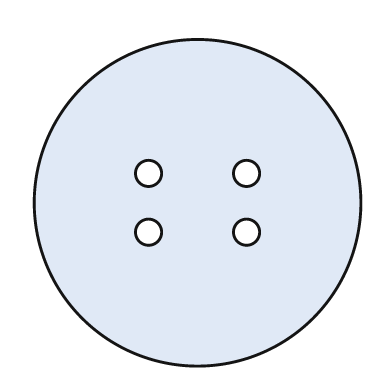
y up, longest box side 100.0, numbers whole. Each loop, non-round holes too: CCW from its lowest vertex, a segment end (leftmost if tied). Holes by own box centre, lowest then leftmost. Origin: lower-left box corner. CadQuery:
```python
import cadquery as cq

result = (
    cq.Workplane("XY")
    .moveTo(50.0, 50.0)
    .circle(50.0)
    .moveTo(35.0, 41.0)
    .circle(4.0)
    .moveTo(65.0, 41.0)
    .circle(4.0)
    .moveTo(35.0, 59.0)
    .circle(4.0)
    .moveTo(65.0, 59.0)
    .circle(4.0)
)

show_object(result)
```